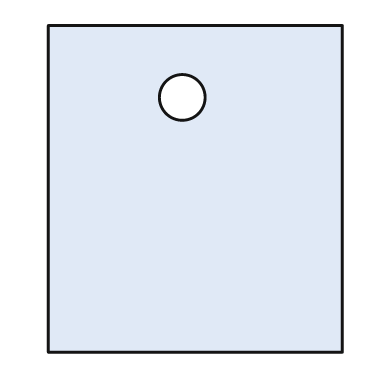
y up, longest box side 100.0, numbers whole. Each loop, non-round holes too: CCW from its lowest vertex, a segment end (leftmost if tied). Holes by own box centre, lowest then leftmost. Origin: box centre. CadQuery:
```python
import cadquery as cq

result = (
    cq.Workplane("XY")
    .moveTo(-45.0, -50.0)
    .lineTo(45.0, -50.0)
    .lineTo(45.0, 50.0)
    .lineTo(-45.0, 50.0)
    .close()
    .moveTo(-4.0, 28.0)
    .circle(7.0)
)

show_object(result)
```